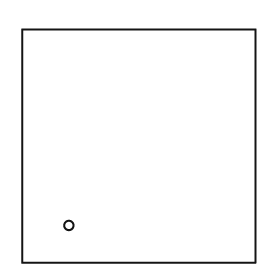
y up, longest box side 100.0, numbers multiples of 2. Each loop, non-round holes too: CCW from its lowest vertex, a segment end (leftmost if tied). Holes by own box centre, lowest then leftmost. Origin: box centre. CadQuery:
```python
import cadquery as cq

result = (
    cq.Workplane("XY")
    .moveTo(-50.0, -50.0)
    .lineTo(50.0, -50.0)
    .lineTo(50.0, 50.0)
    .lineTo(-50.0, 50.0)
    .close()
    .moveTo(-30.0, -34.0)
    .circle(2.0)
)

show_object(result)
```